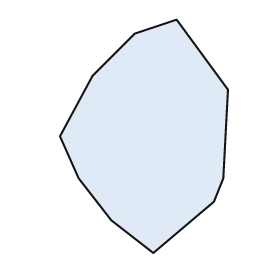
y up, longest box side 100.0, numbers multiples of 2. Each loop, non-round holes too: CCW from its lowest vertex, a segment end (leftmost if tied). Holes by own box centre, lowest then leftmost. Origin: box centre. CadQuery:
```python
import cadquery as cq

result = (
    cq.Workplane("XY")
    .moveTo(4.0, -50.0)
    .lineTo(30.0, -28.0)
    .lineTo(34.0, -18.0)
    .lineTo(36.0, 20.0)
    .lineTo(14.0, 50.0)
    .lineTo(-4.0, 44.0)
    .lineTo(-22.0, 26.0)
    .lineTo(-36.0, 0.0)
    .lineTo(-28.0, -18.0)
    .lineTo(-14.0, -36.0)
    .close()
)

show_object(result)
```